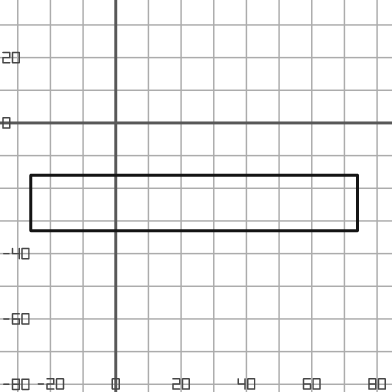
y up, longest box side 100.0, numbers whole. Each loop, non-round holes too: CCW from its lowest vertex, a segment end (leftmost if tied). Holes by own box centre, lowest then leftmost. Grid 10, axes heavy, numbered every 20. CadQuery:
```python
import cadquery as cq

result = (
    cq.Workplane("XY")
    .moveTo(-26.0, -33.0)
    .lineTo(74.0, -33.0)
    .lineTo(74.0, -16.0)
    .lineTo(-26.0, -16.0)
    .close()
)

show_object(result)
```